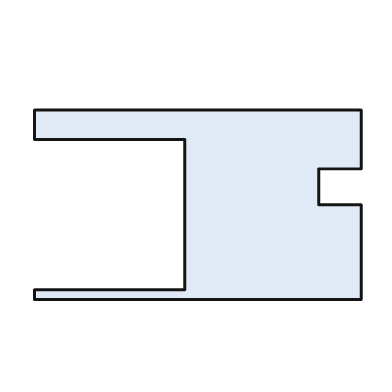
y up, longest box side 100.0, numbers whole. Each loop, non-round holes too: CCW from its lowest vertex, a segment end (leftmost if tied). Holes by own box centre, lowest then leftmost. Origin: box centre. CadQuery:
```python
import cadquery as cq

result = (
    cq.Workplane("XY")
    .moveTo(-50.0, -29.0)
    .lineTo(50.0, -29.0)
    .lineTo(50.0, 0.0)
    .lineTo(37.0, 0.0)
    .lineTo(37.0, 11.0)
    .lineTo(50.0, 11.0)
    .lineTo(50.0, 29.0)
    .lineTo(-50.0, 29.0)
    .lineTo(-50.0, 20.0)
    .lineTo(-4.0, 20.0)
    .lineTo(-4.0, -26.0)
    .lineTo(-50.0, -26.0)
    .close()
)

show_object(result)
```